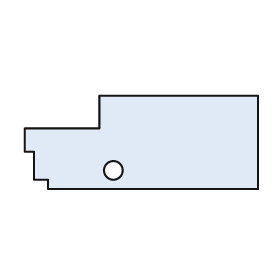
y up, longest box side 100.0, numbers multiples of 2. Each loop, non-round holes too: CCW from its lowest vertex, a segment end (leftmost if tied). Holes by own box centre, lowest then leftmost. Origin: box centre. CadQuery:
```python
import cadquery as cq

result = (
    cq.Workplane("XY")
    .moveTo(-40.0, -20.0)
    .lineTo(50.0, -20.0)
    .lineTo(50.0, 20.0)
    .lineTo(-18.0, 20.0)
    .lineTo(-18.0, 6.0)
    .lineTo(-50.0, 6.0)
    .lineTo(-50.0, -4.0)
    .lineTo(-46.0, -4.0)
    .lineTo(-46.0, -16.0)
    .lineTo(-40.0, -16.0)
    .close()
    .moveTo(-12.0, -12.0)
    .circle(4.0)
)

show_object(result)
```